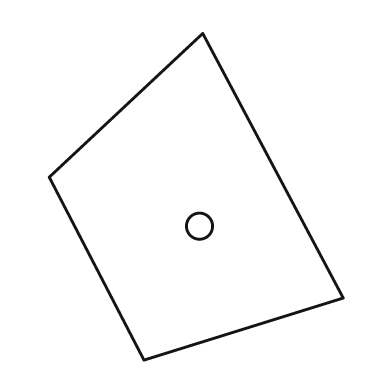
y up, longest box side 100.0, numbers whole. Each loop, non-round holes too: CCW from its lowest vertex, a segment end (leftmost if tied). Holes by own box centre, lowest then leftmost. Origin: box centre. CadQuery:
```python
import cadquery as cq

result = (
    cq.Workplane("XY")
    .moveTo(-16.0, -50.0)
    .lineTo(45.0, -31.0)
    .lineTo(2.0, 50.0)
    .lineTo(-45.0, 6.0)
    .close()
    .moveTo(1.0, -9.0)
    .circle(4.0)
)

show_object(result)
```